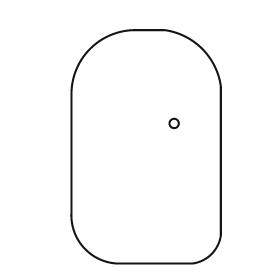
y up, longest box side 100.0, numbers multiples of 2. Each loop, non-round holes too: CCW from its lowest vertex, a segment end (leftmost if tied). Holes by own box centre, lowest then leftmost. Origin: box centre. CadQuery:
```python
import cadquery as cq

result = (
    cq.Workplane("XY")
    .moveTo(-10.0, -50.0)
    .lineTo(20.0, -50.0)
    .threePointArc((28.0, -46.0), (32.0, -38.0))
    .lineTo(32.0, 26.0)
    .threePointArc((24.0, 42.0), (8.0, 50.0))
    .lineTo(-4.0, 50.0)
    .threePointArc((-24.0, 42.0), (-32.0, 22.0))
    .lineTo(-32.0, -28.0)
    .threePointArc((-26.0, -44.0), (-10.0, -50.0))
    .close()
    .moveTo(12.0, 10.0)
    .circle(2.0)
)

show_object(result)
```